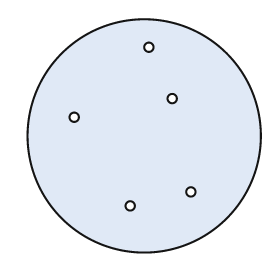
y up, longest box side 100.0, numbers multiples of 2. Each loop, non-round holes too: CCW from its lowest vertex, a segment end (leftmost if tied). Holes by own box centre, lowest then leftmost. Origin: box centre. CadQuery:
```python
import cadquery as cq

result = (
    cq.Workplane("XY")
    .moveTo(0.0, 0.0)
    .circle(50.0)
    .moveTo(-6.0, -30.0)
    .circle(2.0)
    .moveTo(20.0, -24.0)
    .circle(2.0)
    .moveTo(-30.0, 8.0)
    .circle(2.0)
    .moveTo(12.0, 16.0)
    .circle(2.0)
    .moveTo(2.0, 38.0)
    .circle(2.0)
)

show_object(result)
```